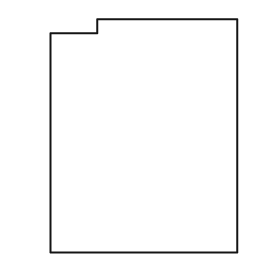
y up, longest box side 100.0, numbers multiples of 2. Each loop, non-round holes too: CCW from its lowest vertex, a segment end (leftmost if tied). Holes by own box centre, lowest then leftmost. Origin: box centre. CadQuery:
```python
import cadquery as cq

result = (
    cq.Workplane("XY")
    .moveTo(-40.0, -50.0)
    .lineTo(40.0, -50.0)
    .lineTo(40.0, 50.0)
    .lineTo(-20.0, 50.0)
    .lineTo(-20.0, 44.0)
    .lineTo(-40.0, 44.0)
    .close()
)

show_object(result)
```